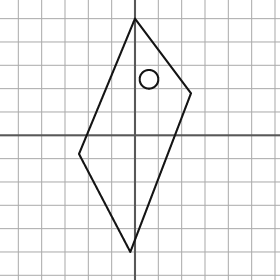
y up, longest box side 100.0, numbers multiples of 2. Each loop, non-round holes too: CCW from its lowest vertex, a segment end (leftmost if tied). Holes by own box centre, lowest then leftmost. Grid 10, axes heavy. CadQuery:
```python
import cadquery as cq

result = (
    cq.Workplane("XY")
    .moveTo(-2.0, -50.0)
    .lineTo(24.0, 18.0)
    .lineTo(0.0, 50.0)
    .lineTo(-24.0, -8.0)
    .close()
    .moveTo(6.0, 24.0)
    .circle(4.0)
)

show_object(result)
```